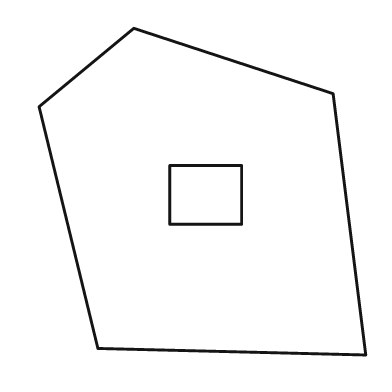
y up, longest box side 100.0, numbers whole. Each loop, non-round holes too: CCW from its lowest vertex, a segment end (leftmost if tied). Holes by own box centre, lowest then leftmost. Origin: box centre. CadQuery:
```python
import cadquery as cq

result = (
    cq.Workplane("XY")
    .moveTo(50.0, -50.0)
    .lineTo(40.0, 30.0)
    .lineTo(-21.0, 50.0)
    .lineTo(-50.0, 26.0)
    .lineTo(-32.0, -48.0)
    .close()
    .moveTo(-10.0, -10.0)
    .lineTo(12.0, -10.0)
    .lineTo(12.0, 8.0)
    .lineTo(-10.0, 8.0)
    .close()
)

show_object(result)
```